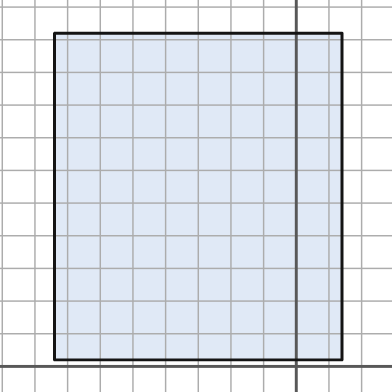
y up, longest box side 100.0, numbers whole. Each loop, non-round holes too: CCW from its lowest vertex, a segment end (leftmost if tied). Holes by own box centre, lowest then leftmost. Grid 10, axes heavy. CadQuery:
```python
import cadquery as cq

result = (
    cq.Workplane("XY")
    .moveTo(-74.0, 2.0)
    .lineTo(14.0, 2.0)
    .lineTo(14.0, 102.0)
    .lineTo(-74.0, 102.0)
    .close()
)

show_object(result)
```